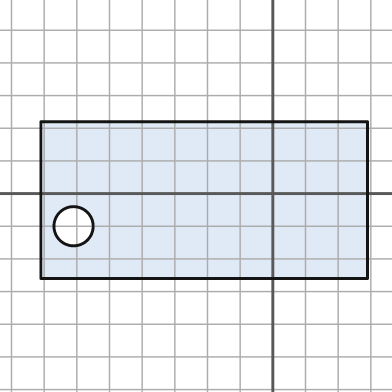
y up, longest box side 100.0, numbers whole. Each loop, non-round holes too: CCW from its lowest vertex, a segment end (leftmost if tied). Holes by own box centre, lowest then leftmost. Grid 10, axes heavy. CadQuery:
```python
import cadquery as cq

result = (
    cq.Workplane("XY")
    .moveTo(-71.0, -26.0)
    .lineTo(29.0, -26.0)
    .lineTo(29.0, 22.0)
    .lineTo(-71.0, 22.0)
    .close()
    .moveTo(-61.0, -10.0)
    .circle(6.0)
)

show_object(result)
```